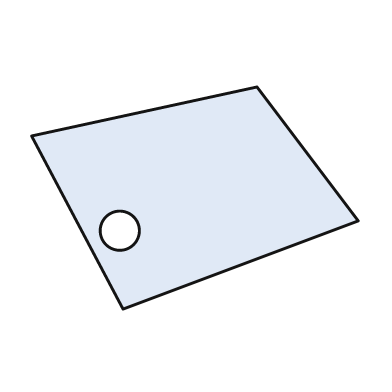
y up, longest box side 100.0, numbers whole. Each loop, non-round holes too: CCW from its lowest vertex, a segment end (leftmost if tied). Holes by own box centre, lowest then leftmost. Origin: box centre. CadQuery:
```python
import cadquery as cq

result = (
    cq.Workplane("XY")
    .moveTo(-22.0, -34.0)
    .lineTo(50.0, -7.0)
    .lineTo(19.0, 34.0)
    .lineTo(-50.0, 19.0)
    .close()
    .moveTo(-23.0, -10.0)
    .circle(6.0)
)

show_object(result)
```